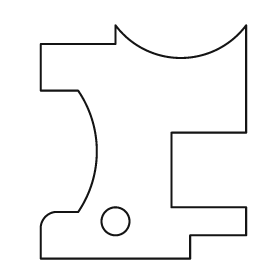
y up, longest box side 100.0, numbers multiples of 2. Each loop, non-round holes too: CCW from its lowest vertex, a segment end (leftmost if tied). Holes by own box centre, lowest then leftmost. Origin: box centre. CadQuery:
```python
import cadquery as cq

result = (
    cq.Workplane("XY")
    .moveTo(-44.0, -50.0)
    .lineTo(20.0, -50.0)
    .lineTo(20.0, -40.0)
    .lineTo(44.0, -40.0)
    .lineTo(44.0, -28.0)
    .lineTo(12.0, -28.0)
    .lineTo(12.0, 4.0)
    .lineTo(44.0, 4.0)
    .lineTo(44.0, 50.0)
    .threePointArc((16.0, 36.0), (-12.0, 50.0))
    .lineTo(-12.0, 42.0)
    .lineTo(-44.0, 42.0)
    .lineTo(-44.0, 22.0)
    .lineTo(-28.0, 22.0)
    .threePointArc((-20.0, -4.0), (-28.0, -30.0))
    .lineTo(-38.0, -30.0)
    .threePointArc((-42.0, -32.0), (-44.0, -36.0))
    .close()
    .moveTo(-12.0, -34.0)
    .circle(6.0)
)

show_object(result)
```